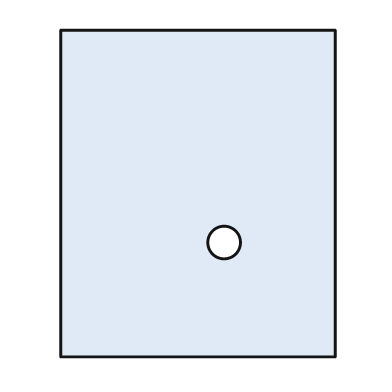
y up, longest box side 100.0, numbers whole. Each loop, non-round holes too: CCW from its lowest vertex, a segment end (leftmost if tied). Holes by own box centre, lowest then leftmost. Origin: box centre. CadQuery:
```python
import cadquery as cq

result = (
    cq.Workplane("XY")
    .moveTo(-42.0, -50.0)
    .lineTo(42.0, -50.0)
    .lineTo(42.0, 50.0)
    .lineTo(-42.0, 50.0)
    .close()
    .moveTo(8.0, -15.0)
    .circle(5.0)
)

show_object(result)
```